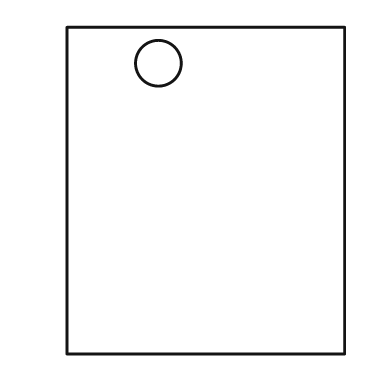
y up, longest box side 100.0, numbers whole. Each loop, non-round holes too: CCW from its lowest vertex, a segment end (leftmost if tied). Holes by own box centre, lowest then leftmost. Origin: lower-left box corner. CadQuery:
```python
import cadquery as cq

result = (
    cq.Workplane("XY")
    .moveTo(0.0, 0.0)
    .lineTo(85.0, 0.0)
    .lineTo(85.0, 100.0)
    .lineTo(0.0, 100.0)
    .close()
    .moveTo(28.0, 89.0)
    .circle(7.0)
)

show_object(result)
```